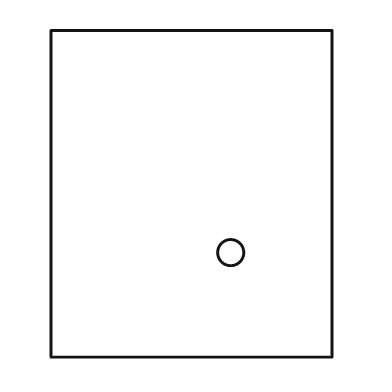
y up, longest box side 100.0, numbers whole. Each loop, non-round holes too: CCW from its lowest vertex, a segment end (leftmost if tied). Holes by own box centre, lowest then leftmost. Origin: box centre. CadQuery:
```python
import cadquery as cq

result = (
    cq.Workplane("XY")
    .moveTo(-43.0, -50.0)
    .lineTo(43.0, -50.0)
    .lineTo(43.0, 50.0)
    .lineTo(-43.0, 50.0)
    .close()
    .moveTo(12.0, -18.0)
    .circle(4.0)
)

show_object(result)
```